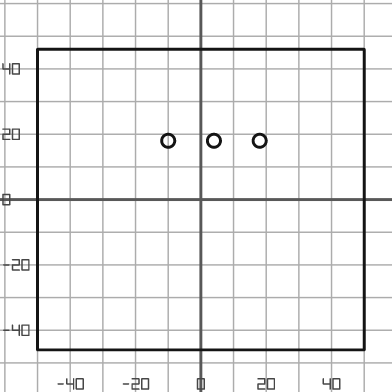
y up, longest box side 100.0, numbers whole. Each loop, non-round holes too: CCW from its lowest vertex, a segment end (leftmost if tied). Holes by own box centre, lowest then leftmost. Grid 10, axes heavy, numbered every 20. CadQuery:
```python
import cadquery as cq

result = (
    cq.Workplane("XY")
    .moveTo(-50.0, -46.0)
    .lineTo(50.0, -46.0)
    .lineTo(50.0, 46.0)
    .lineTo(-50.0, 46.0)
    .close()
    .moveTo(-10.0, 18.0)
    .circle(2.0)
    .moveTo(4.0, 18.0)
    .circle(2.0)
    .moveTo(18.0, 18.0)
    .circle(2.0)
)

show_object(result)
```